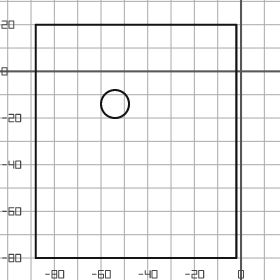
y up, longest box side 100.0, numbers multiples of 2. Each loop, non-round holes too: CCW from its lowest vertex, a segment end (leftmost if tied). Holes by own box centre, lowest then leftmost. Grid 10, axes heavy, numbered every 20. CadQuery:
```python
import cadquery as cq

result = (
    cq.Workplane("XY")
    .moveTo(-88.0, -80.0)
    .lineTo(-2.0, -80.0)
    .lineTo(-2.0, 20.0)
    .lineTo(-88.0, 20.0)
    .close()
    .moveTo(-54.0, -14.0)
    .circle(6.0)
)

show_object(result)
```